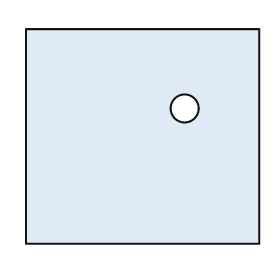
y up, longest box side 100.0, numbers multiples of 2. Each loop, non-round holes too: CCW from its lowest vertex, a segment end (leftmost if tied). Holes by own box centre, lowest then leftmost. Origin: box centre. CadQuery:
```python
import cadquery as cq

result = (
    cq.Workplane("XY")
    .moveTo(-50.0, -46.0)
    .lineTo(50.0, -46.0)
    .lineTo(50.0, 46.0)
    .lineTo(-50.0, 46.0)
    .close()
    .moveTo(18.0, 12.0)
    .circle(6.0)
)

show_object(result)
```